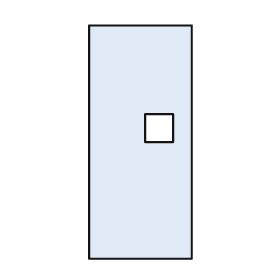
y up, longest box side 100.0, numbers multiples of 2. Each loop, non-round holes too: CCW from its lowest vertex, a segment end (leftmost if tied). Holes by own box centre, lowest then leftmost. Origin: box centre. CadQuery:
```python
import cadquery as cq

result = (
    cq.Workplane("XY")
    .moveTo(-22.0, -50.0)
    .lineTo(22.0, -50.0)
    .lineTo(22.0, 50.0)
    .lineTo(-22.0, 50.0)
    .close()
    .moveTo(2.0, 0.0)
    .lineTo(14.0, 0.0)
    .lineTo(14.0, 12.0)
    .lineTo(2.0, 12.0)
    .close()
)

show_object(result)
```